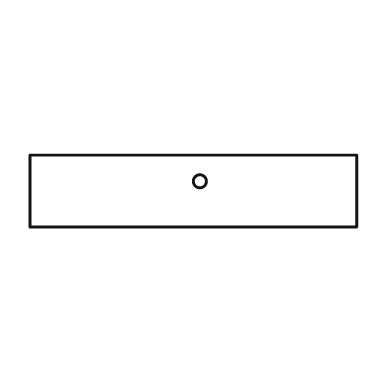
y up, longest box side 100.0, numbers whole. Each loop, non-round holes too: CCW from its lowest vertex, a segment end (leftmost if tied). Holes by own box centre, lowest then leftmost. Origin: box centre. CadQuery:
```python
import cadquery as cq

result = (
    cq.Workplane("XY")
    .moveTo(-50.0, -11.0)
    .lineTo(50.0, -11.0)
    .lineTo(50.0, 11.0)
    .lineTo(-50.0, 11.0)
    .close()
    .moveTo(2.0, 3.0)
    .circle(2.0)
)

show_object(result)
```